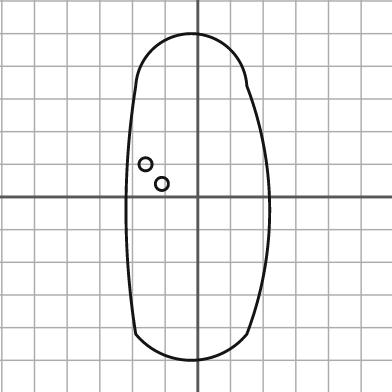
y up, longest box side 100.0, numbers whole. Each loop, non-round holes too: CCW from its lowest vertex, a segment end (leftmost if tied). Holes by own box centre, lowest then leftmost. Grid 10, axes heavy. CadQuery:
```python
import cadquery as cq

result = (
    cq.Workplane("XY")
    .moveTo(-19.0, -42.0)
    .threePointArc((-2.0, -50.0), (15.0, -42.0))
    .threePointArc((22.0, -4.0), (15.0, 34.0))
    .threePointArc((-2.0, 50.0), (-19.0, 34.0))
    .threePointArc((-22.0, -4.0), (-19.0, -42.0))
    .close()
    .moveTo(-11.0, 4.0)
    .circle(2.0)
    .moveTo(-16.0, 10.0)
    .circle(2.0)
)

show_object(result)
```